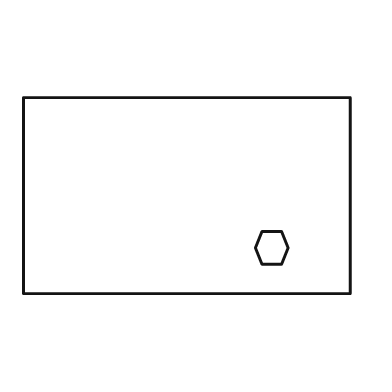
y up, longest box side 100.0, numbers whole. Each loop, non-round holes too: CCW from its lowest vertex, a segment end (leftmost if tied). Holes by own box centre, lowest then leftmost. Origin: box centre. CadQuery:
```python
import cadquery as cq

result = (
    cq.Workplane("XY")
    .moveTo(-50.0, -30.0)
    .lineTo(50.0, -30.0)
    .lineTo(50.0, 30.0)
    .lineTo(-50.0, 30.0)
    .close()
    .moveTo(23.0, -21.0)
    .lineTo(29.0, -21.0)
    .lineTo(31.0, -16.0)
    .lineTo(29.0, -11.0)
    .lineTo(23.0, -11.0)
    .lineTo(21.0, -16.0)
    .close()
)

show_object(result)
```